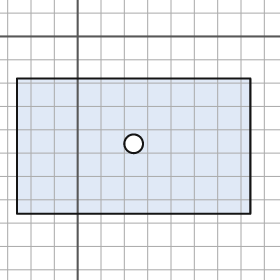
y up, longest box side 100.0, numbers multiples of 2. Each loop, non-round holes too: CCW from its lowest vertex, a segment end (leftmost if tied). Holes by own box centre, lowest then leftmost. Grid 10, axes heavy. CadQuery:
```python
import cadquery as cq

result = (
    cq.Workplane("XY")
    .moveTo(-26.0, -76.0)
    .lineTo(74.0, -76.0)
    .lineTo(74.0, -18.0)
    .lineTo(-26.0, -18.0)
    .close()
    .moveTo(24.0, -46.0)
    .circle(4.0)
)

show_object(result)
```